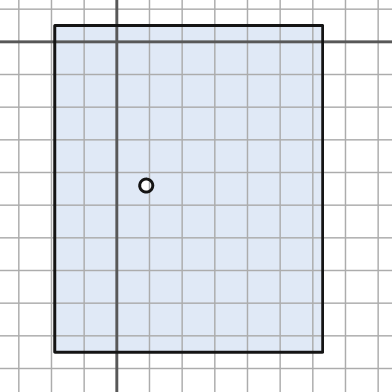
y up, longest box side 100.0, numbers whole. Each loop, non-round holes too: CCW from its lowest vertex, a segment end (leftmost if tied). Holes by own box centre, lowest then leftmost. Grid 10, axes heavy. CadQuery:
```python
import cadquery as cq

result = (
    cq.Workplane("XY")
    .moveTo(-19.0, -95.0)
    .lineTo(63.0, -95.0)
    .lineTo(63.0, 5.0)
    .lineTo(-19.0, 5.0)
    .close()
    .moveTo(9.0, -44.0)
    .circle(2.0)
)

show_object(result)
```